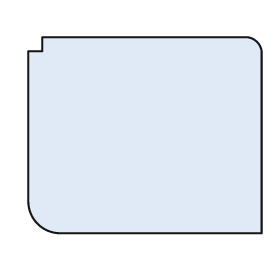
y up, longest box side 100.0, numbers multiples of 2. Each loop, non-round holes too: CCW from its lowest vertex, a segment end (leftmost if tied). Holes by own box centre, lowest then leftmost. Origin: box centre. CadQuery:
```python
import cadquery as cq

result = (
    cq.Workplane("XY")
    .moveTo(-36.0, -42.0)
    .lineTo(50.0, -42.0)
    .lineTo(50.0, 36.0)
    .threePointArc((48.0, 40.0), (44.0, 42.0))
    .lineTo(-44.0, 42.0)
    .lineTo(-44.0, 36.0)
    .lineTo(-50.0, 36.0)
    .lineTo(-50.0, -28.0)
    .threePointArc((-46.0, -38.0), (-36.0, -42.0))
    .close()
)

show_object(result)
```